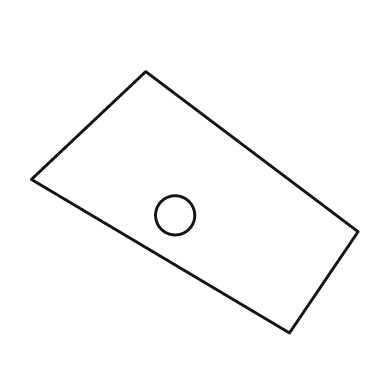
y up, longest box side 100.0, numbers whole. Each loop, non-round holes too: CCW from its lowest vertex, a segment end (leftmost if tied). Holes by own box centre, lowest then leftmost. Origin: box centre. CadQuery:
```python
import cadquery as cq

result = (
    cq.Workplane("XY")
    .moveTo(29.0, -40.0)
    .lineTo(50.0, -9.0)
    .lineTo(-15.0, 40.0)
    .lineTo(-50.0, 7.0)
    .close()
    .moveTo(-6.0, -4.0)
    .circle(6.0)
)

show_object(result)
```